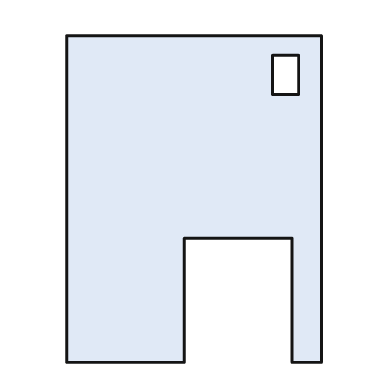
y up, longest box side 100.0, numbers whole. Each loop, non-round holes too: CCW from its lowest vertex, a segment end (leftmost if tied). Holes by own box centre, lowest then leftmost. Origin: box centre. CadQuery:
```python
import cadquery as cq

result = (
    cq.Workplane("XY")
    .moveTo(-39.0, -50.0)
    .lineTo(-3.0, -50.0)
    .lineTo(-3.0, -12.0)
    .lineTo(30.0, -12.0)
    .lineTo(30.0, -50.0)
    .lineTo(39.0, -50.0)
    .lineTo(39.0, 50.0)
    .lineTo(-39.0, 50.0)
    .close()
    .moveTo(24.0, 32.0)
    .lineTo(32.0, 32.0)
    .lineTo(32.0, 44.0)
    .lineTo(24.0, 44.0)
    .close()
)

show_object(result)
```